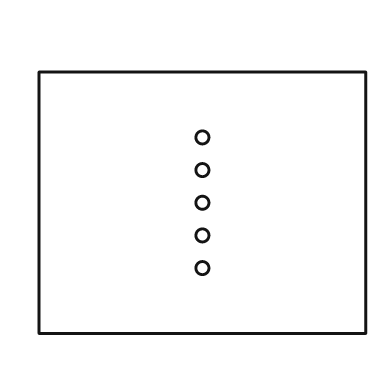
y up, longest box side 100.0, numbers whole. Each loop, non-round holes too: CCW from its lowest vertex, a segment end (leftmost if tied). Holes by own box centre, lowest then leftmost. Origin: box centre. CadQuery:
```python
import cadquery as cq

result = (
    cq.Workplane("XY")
    .moveTo(-50.0, -40.0)
    .lineTo(50.0, -40.0)
    .lineTo(50.0, 40.0)
    .lineTo(-50.0, 40.0)
    .close()
    .moveTo(0.0, -20.0)
    .circle(2.0)
    .moveTo(0.0, -10.0)
    .circle(2.0)
    .moveTo(0.0, 0.0)
    .circle(2.0)
    .moveTo(0.0, 10.0)
    .circle(2.0)
    .moveTo(0.0, 20.0)
    .circle(2.0)
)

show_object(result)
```